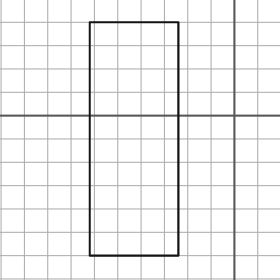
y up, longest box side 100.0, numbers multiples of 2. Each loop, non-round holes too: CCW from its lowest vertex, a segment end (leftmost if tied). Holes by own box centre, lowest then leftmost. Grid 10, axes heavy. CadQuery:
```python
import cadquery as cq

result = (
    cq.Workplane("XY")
    .moveTo(-62.0, -60.0)
    .lineTo(-24.0, -60.0)
    .lineTo(-24.0, 40.0)
    .lineTo(-62.0, 40.0)
    .close()
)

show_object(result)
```